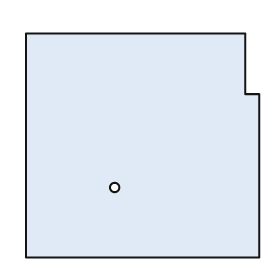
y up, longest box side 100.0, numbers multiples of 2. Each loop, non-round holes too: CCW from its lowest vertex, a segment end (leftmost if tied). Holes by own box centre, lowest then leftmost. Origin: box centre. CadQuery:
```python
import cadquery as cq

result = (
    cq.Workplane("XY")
    .moveTo(-50.0, -48.0)
    .lineTo(50.0, -48.0)
    .lineTo(50.0, 22.0)
    .lineTo(44.0, 22.0)
    .lineTo(44.0, 48.0)
    .lineTo(-50.0, 48.0)
    .close()
    .moveTo(-12.0, -18.0)
    .circle(2.0)
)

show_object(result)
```